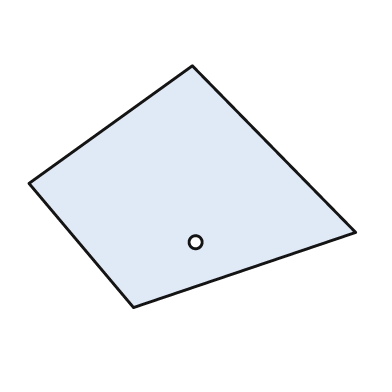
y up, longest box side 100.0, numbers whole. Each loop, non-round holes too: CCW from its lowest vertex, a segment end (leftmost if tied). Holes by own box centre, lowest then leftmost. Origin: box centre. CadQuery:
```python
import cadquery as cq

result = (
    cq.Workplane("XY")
    .moveTo(-18.0, -37.0)
    .lineTo(50.0, -14.0)
    .lineTo(0.0, 37.0)
    .lineTo(-50.0, 1.0)
    .close()
    .moveTo(1.0, -17.0)
    .circle(2.0)
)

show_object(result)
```